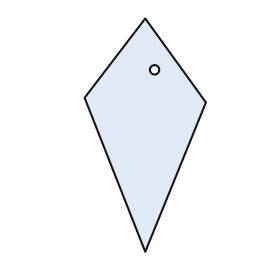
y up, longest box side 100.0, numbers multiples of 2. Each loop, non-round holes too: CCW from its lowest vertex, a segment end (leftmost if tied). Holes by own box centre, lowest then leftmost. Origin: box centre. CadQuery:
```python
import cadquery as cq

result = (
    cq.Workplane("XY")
    .moveTo(0.0, -50.0)
    .lineTo(26.0, 14.0)
    .lineTo(0.0, 50.0)
    .lineTo(-26.0, 16.0)
    .close()
    .moveTo(4.0, 28.0)
    .circle(2.0)
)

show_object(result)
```